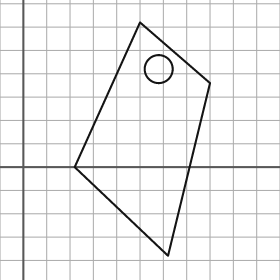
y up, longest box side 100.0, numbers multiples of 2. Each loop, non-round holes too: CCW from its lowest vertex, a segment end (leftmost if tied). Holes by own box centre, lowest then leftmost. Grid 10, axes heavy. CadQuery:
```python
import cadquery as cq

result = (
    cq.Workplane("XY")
    .moveTo(62.0, -38.0)
    .lineTo(80.0, 36.0)
    .lineTo(50.0, 62.0)
    .lineTo(22.0, 0.0)
    .close()
    .moveTo(58.0, 42.0)
    .circle(6.0)
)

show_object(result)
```